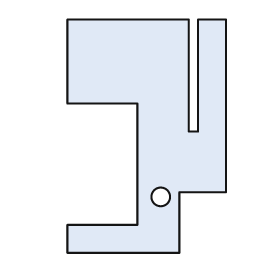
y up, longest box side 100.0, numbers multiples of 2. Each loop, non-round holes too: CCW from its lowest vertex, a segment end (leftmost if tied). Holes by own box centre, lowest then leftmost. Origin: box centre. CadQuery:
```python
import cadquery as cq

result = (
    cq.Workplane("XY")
    .moveTo(-34.0, -50.0)
    .lineTo(14.0, -50.0)
    .lineTo(14.0, -24.0)
    .lineTo(34.0, -24.0)
    .lineTo(34.0, 50.0)
    .lineTo(22.0, 50.0)
    .lineTo(22.0, 2.0)
    .lineTo(18.0, 2.0)
    .lineTo(18.0, 50.0)
    .lineTo(-34.0, 50.0)
    .lineTo(-34.0, 14.0)
    .lineTo(-4.0, 14.0)
    .lineTo(-4.0, -38.0)
    .lineTo(-34.0, -38.0)
    .close()
    .moveTo(6.0, -26.0)
    .circle(4.0)
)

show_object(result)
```